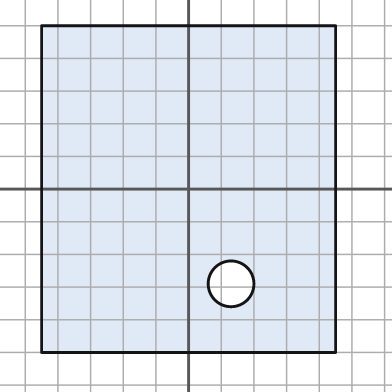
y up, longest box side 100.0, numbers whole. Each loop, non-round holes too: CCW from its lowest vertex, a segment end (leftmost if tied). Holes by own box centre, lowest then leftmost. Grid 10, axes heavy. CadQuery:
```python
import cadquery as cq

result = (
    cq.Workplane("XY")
    .moveTo(-45.0, -50.0)
    .lineTo(45.0, -50.0)
    .lineTo(45.0, 50.0)
    .lineTo(-45.0, 50.0)
    .close()
    .moveTo(13.0, -29.0)
    .circle(7.0)
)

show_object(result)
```